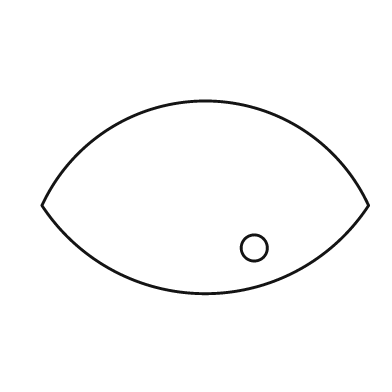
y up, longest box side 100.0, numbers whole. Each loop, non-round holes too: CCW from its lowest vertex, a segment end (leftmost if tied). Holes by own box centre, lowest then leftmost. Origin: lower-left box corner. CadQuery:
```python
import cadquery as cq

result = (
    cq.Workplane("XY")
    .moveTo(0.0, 27.0)
    .threePointArc((50.0, 0.0), (100.0, 27.0))
    .threePointArc((50.0, 59.0), (0.0, 27.0))
    .close()
    .moveTo(65.0, 14.0)
    .circle(4.0)
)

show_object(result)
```